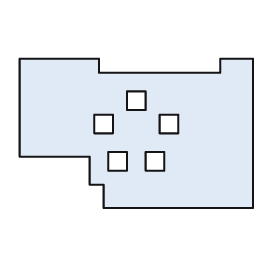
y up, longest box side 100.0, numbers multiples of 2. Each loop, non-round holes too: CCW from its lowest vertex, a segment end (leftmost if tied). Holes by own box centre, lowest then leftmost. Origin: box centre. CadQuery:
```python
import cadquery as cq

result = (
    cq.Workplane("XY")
    .moveTo(-14.0, -32.0)
    .lineTo(50.0, -32.0)
    .lineTo(50.0, 32.0)
    .lineTo(36.0, 32.0)
    .lineTo(36.0, 26.0)
    .lineTo(-16.0, 26.0)
    .lineTo(-16.0, 32.0)
    .lineTo(-50.0, 32.0)
    .lineTo(-50.0, -10.0)
    .lineTo(-20.0, -10.0)
    .lineTo(-20.0, -22.0)
    .lineTo(-14.0, -22.0)
    .close()
    .moveTo(-12.0, -16.0)
    .lineTo(-4.0, -16.0)
    .lineTo(-4.0, -8.0)
    .lineTo(-12.0, -8.0)
    .close()
    .moveTo(4.0, -16.0)
    .lineTo(12.0, -16.0)
    .lineTo(12.0, -8.0)
    .lineTo(4.0, -8.0)
    .close()
    .moveTo(-18.0, 0.0)
    .lineTo(-10.0, 0.0)
    .lineTo(-10.0, 8.0)
    .lineTo(-18.0, 8.0)
    .close()
    .moveTo(10.0, 0.0)
    .lineTo(18.0, 0.0)
    .lineTo(18.0, 8.0)
    .lineTo(10.0, 8.0)
    .close()
    .moveTo(-4.0, 10.0)
    .lineTo(4.0, 10.0)
    .lineTo(4.0, 18.0)
    .lineTo(-4.0, 18.0)
    .close()
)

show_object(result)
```